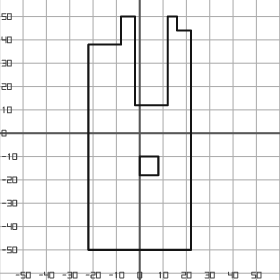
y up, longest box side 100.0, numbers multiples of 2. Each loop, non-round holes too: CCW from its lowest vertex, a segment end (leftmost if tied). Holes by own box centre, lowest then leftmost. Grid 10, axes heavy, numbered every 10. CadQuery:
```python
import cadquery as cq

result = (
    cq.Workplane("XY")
    .moveTo(-22.0, -50.0)
    .lineTo(22.0, -50.0)
    .lineTo(22.0, 44.0)
    .lineTo(16.0, 44.0)
    .lineTo(16.0, 50.0)
    .lineTo(12.0, 50.0)
    .lineTo(12.0, 12.0)
    .lineTo(-2.0, 12.0)
    .lineTo(-2.0, 50.0)
    .lineTo(-8.0, 50.0)
    .lineTo(-8.0, 38.0)
    .lineTo(-22.0, 38.0)
    .close()
    .moveTo(0.0, -18.0)
    .lineTo(8.0, -18.0)
    .lineTo(8.0, -10.0)
    .lineTo(0.0, -10.0)
    .close()
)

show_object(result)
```